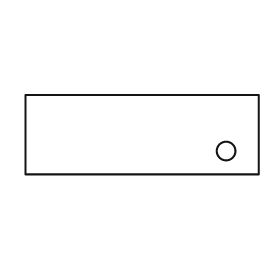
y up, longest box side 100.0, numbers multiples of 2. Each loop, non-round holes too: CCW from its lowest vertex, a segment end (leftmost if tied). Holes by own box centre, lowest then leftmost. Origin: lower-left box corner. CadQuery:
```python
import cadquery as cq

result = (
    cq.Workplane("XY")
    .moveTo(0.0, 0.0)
    .lineTo(100.0, 0.0)
    .lineTo(100.0, 34.0)
    .lineTo(0.0, 34.0)
    .close()
    .moveTo(86.0, 10.0)
    .circle(4.0)
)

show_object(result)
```